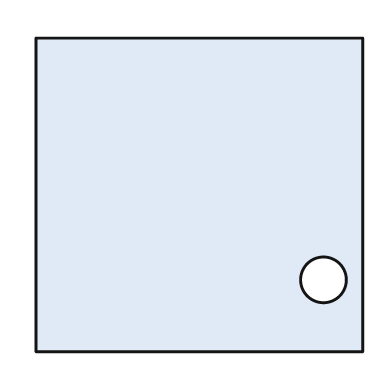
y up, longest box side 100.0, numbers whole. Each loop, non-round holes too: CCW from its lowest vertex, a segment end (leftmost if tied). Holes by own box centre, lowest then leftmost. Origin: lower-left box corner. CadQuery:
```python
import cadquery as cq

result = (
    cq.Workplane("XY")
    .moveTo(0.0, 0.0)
    .lineTo(100.0, 0.0)
    .lineTo(100.0, 96.0)
    .lineTo(0.0, 96.0)
    .close()
    .moveTo(88.0, 22.0)
    .circle(7.0)
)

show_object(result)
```